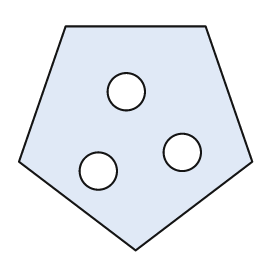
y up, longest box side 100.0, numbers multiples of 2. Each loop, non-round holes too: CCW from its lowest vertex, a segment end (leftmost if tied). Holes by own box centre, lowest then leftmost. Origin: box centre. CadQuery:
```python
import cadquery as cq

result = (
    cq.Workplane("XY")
    .moveTo(0.0, -48.0)
    .lineTo(50.0, -10.0)
    .lineTo(30.0, 48.0)
    .lineTo(-30.0, 48.0)
    .lineTo(-50.0, -10.0)
    .close()
    .moveTo(-16.0, -14.0)
    .circle(8.0)
    .moveTo(20.0, -6.0)
    .circle(8.0)
    .moveTo(-4.0, 20.0)
    .circle(8.0)
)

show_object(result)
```